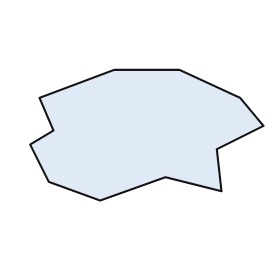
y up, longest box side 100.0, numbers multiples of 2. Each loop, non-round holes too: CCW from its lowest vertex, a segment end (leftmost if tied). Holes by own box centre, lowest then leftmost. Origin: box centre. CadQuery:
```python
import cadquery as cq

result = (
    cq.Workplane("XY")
    .moveTo(-20.0, -28.0)
    .lineTo(8.0, -18.0)
    .lineTo(32.0, -24.0)
    .lineTo(30.0, -6.0)
    .lineTo(50.0, 4.0)
    .lineTo(40.0, 16.0)
    .lineTo(14.0, 28.0)
    .lineTo(-14.0, 28.0)
    .lineTo(-46.0, 16.0)
    .lineTo(-40.0, 2.0)
    .lineTo(-50.0, -4.0)
    .lineTo(-42.0, -20.0)
    .close()
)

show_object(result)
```